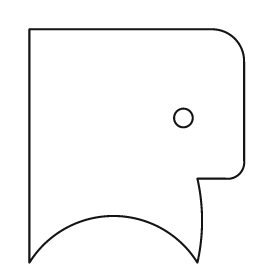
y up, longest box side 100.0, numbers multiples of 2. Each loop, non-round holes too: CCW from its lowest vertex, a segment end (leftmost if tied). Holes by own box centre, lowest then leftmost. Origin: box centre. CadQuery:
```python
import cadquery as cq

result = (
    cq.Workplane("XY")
    .moveTo(-46.0, -50.0)
    .threePointArc((-10.0, -30.0), (26.0, -50.0))
    .threePointArc((28.0, -32.0), (26.0, -14.0))
    .lineTo(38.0, -14.0)
    .threePointArc((44.0, -12.0), (46.0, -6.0))
    .lineTo(46.0, 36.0)
    .threePointArc((42.0, 46.0), (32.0, 50.0))
    .lineTo(-46.0, 50.0)
    .close()
    .moveTo(20.0, 12.0)
    .circle(4.0)
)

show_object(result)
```